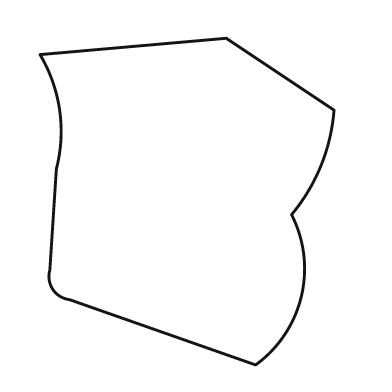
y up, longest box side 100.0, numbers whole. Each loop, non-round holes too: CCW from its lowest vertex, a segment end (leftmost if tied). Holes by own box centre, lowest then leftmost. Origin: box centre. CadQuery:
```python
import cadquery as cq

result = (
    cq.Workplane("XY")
    .moveTo(21.0, -50.0)
    .threePointArc((35.0, -29.0), (32.0, -4.0))
    .threePointArc((41.0, 11.0), (45.0, 28.0))
    .lineTo(12.0, 50.0)
    .lineTo(-45.0, 45.0)
    .threePointArc((-39.0, 28.0), (-40.0, 10.0))
    .lineTo(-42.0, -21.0)
    .threePointArc((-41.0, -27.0), (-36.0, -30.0))
    .close()
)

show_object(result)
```